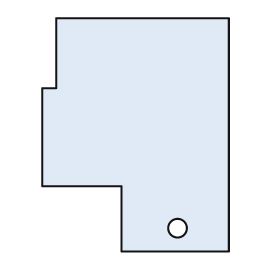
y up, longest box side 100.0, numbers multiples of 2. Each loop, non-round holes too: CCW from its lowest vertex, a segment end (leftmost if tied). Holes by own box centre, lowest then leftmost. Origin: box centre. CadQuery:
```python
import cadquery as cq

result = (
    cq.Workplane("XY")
    .moveTo(-6.0, -50.0)
    .lineTo(40.0, -50.0)
    .lineTo(40.0, 50.0)
    .lineTo(-34.0, 50.0)
    .lineTo(-34.0, 20.0)
    .lineTo(-40.0, 20.0)
    .lineTo(-40.0, -22.0)
    .lineTo(-6.0, -22.0)
    .close()
    .moveTo(18.0, -40.0)
    .circle(4.0)
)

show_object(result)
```